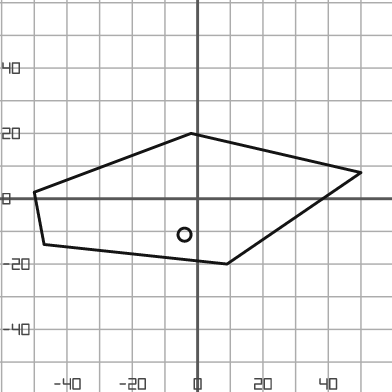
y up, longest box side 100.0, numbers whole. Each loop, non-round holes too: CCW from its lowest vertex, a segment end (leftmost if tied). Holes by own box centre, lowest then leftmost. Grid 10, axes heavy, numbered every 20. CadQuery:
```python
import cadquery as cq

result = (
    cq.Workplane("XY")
    .moveTo(9.0, -20.0)
    .lineTo(50.0, 8.0)
    .lineTo(-2.0, 20.0)
    .lineTo(-50.0, 2.0)
    .lineTo(-47.0, -14.0)
    .close()
    .moveTo(-4.0, -11.0)
    .circle(2.0)
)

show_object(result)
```